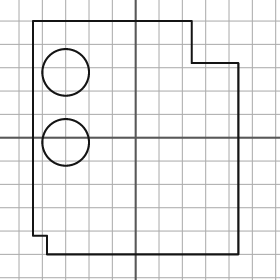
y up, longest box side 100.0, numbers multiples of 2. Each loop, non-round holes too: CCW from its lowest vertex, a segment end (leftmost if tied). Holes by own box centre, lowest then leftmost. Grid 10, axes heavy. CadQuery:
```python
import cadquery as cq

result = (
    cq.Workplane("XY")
    .moveTo(-38.0, -50.0)
    .lineTo(44.0, -50.0)
    .lineTo(44.0, 32.0)
    .lineTo(24.0, 32.0)
    .lineTo(24.0, 50.0)
    .lineTo(-44.0, 50.0)
    .lineTo(-44.0, -42.0)
    .lineTo(-38.0, -42.0)
    .close()
    .moveTo(-30.0, -2.0)
    .circle(10.0)
    .moveTo(-30.0, 28.0)
    .circle(10.0)
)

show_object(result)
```